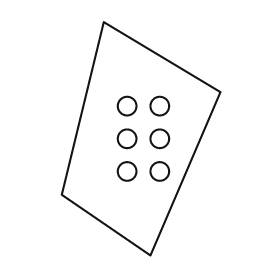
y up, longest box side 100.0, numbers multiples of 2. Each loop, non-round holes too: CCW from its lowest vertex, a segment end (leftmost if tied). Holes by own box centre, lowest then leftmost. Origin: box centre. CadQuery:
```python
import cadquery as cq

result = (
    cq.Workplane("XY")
    .moveTo(4.0, -50.0)
    .lineTo(34.0, 20.0)
    .lineTo(-16.0, 50.0)
    .lineTo(-34.0, -24.0)
    .close()
    .moveTo(-6.0, -14.0)
    .circle(4.0)
    .moveTo(8.0, -14.0)
    .circle(4.0)
    .moveTo(-6.0, 0.0)
    .circle(4.0)
    .moveTo(8.0, 0.0)
    .circle(4.0)
    .moveTo(-6.0, 14.0)
    .circle(4.0)
    .moveTo(8.0, 14.0)
    .circle(4.0)
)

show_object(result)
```